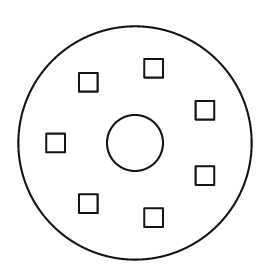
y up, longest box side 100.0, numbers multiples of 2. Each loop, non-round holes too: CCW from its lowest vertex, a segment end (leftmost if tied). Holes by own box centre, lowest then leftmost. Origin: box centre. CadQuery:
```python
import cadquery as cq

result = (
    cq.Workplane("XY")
    .moveTo(0.0, 0.0)
    .circle(50.0)
    .moveTo(4.0, -36.0)
    .lineTo(12.0, -36.0)
    .lineTo(12.0, -28.0)
    .lineTo(4.0, -28.0)
    .close()
    .moveTo(-24.0, -30.0)
    .lineTo(-16.0, -30.0)
    .lineTo(-16.0, -22.0)
    .lineTo(-24.0, -22.0)
    .close()
    .moveTo(26.0, -18.0)
    .lineTo(34.0, -18.0)
    .lineTo(34.0, -10.0)
    .lineTo(26.0, -10.0)
    .close()
    .moveTo(-38.0, -4.0)
    .lineTo(-30.0, -4.0)
    .lineTo(-30.0, 4.0)
    .lineTo(-38.0, 4.0)
    .close()
    .moveTo(0.0, 0.0)
    .circle(12.0)
    .moveTo(26.0, 10.0)
    .lineTo(34.0, 10.0)
    .lineTo(34.0, 18.0)
    .lineTo(26.0, 18.0)
    .close()
    .moveTo(-24.0, 22.0)
    .lineTo(-16.0, 22.0)
    .lineTo(-16.0, 30.0)
    .lineTo(-24.0, 30.0)
    .close()
    .moveTo(4.0, 28.0)
    .lineTo(12.0, 28.0)
    .lineTo(12.0, 36.0)
    .lineTo(4.0, 36.0)
    .close()
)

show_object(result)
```